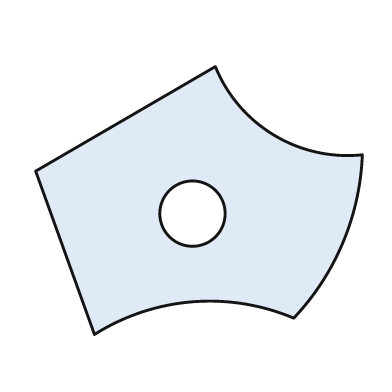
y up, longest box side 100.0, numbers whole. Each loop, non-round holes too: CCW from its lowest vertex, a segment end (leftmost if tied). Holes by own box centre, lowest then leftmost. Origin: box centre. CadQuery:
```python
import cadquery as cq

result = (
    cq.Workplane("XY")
    .moveTo(-32.0, -41.0)
    .threePointArc((-2.0, -31.0), (29.0, -36.0))
    .threePointArc((44.0, -13.0), (50.0, 14.0))
    .threePointArc((23.0, 20.0), (5.0, 41.0))
    .lineTo(-50.0, 9.0)
    .close()
    .moveTo(-2.0, -4.0)
    .circle(10.0)
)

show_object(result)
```